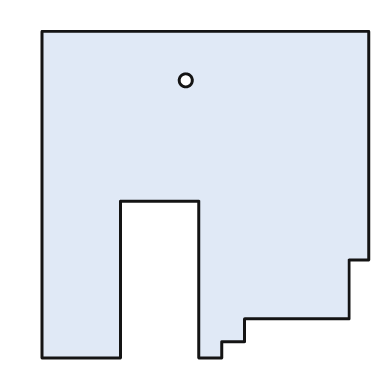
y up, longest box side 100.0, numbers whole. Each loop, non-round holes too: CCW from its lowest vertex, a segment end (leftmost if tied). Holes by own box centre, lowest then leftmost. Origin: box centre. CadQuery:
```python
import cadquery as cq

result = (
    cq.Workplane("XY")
    .moveTo(-50.0, -50.0)
    .lineTo(-26.0, -50.0)
    .lineTo(-26.0, -2.0)
    .lineTo(-2.0, -2.0)
    .lineTo(-2.0, -50.0)
    .lineTo(5.0, -50.0)
    .lineTo(5.0, -45.0)
    .lineTo(12.0, -45.0)
    .lineTo(12.0, -38.0)
    .lineTo(44.0, -38.0)
    .lineTo(44.0, -20.0)
    .lineTo(50.0, -20.0)
    .lineTo(50.0, 50.0)
    .lineTo(-50.0, 50.0)
    .close()
    .moveTo(-6.0, 35.0)
    .circle(2.0)
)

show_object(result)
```